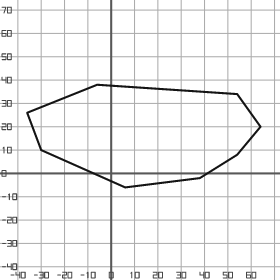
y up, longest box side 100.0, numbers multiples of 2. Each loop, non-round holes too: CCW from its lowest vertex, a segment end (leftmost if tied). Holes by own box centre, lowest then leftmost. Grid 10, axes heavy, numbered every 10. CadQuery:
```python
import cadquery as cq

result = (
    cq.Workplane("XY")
    .moveTo(6.0, -6.0)
    .lineTo(38.0, -2.0)
    .lineTo(54.0, 8.0)
    .lineTo(64.0, 20.0)
    .lineTo(54.0, 34.0)
    .lineTo(-6.0, 38.0)
    .lineTo(-36.0, 26.0)
    .lineTo(-30.0, 10.0)
    .close()
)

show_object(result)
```